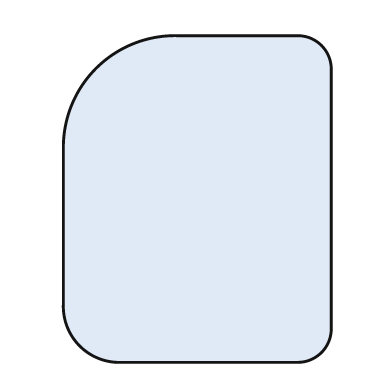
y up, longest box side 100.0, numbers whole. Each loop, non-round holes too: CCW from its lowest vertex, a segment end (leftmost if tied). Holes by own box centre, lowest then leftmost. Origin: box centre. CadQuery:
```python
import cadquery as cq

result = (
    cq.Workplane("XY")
    .moveTo(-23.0, -50.0)
    .lineTo(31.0, -50.0)
    .threePointArc((38.0, -47.0), (41.0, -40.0))
    .lineTo(41.0, 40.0)
    .threePointArc((38.0, 47.0), (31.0, 50.0))
    .lineTo(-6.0, 50.0)
    .threePointArc((-31.0, 40.0), (-41.0, 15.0))
    .lineTo(-41.0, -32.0)
    .threePointArc((-36.0, -45.0), (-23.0, -50.0))
    .close()
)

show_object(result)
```